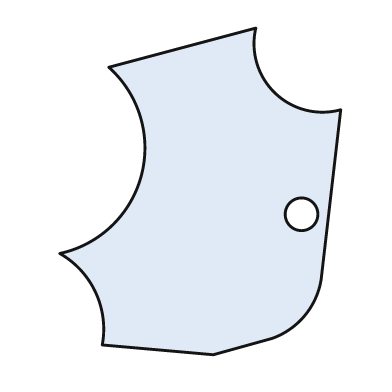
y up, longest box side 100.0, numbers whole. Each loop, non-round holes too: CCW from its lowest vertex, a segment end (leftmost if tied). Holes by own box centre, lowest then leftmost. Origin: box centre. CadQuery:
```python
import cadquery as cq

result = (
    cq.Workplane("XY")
    .moveTo(4.0, -50.0)
    .lineTo(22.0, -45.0)
    .threePointArc((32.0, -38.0), (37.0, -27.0))
    .lineTo(43.0, 25.0)
    .threePointArc((23.0, 30.0), (17.0, 50.0))
    .lineTo(-28.0, 38.0)
    .threePointArc((-18.0, 5.0), (-43.0, -19.0))
    .threePointArc((-32.0, -31.0), (-30.0, -47.0))
    .close()
    .moveTo(31.0, -7.0)
    .circle(5.0)
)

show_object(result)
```